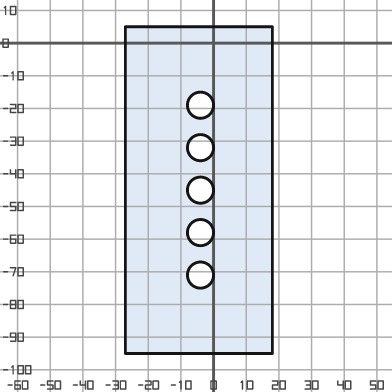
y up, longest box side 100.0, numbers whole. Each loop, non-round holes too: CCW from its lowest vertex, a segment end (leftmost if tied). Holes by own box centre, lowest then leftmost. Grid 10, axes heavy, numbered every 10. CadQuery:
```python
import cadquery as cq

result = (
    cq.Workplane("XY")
    .moveTo(-27.0, -95.0)
    .lineTo(18.0, -95.0)
    .lineTo(18.0, 5.0)
    .lineTo(-27.0, 5.0)
    .close()
    .moveTo(-4.0, -71.0)
    .circle(4.0)
    .moveTo(-4.0, -58.0)
    .circle(4.0)
    .moveTo(-4.0, -45.0)
    .circle(4.0)
    .moveTo(-4.0, -32.0)
    .circle(4.0)
    .moveTo(-4.0, -19.0)
    .circle(4.0)
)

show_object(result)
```